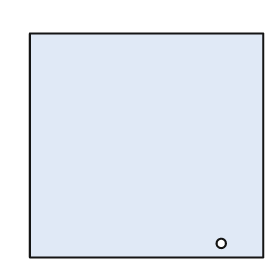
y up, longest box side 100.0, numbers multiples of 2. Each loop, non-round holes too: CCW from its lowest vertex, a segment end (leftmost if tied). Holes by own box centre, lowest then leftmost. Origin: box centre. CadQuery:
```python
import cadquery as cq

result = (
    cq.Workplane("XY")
    .moveTo(-50.0, -48.0)
    .lineTo(50.0, -48.0)
    .lineTo(50.0, 48.0)
    .lineTo(-50.0, 48.0)
    .close()
    .moveTo(32.0, -42.0)
    .circle(2.0)
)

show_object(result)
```